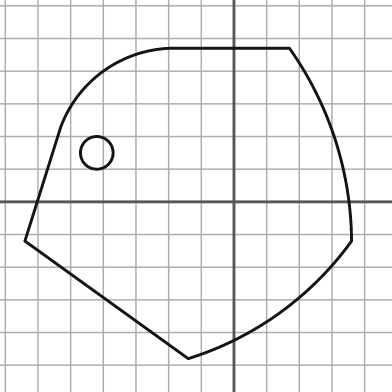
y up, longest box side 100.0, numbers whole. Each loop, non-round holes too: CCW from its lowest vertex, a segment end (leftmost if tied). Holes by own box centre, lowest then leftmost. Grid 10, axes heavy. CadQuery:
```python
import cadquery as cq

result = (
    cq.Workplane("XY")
    .moveTo(-14.0, -48.0)
    .threePointArc((14.0, -34.0), (36.0, -12.0))
    .threePointArc((31.0, 19.0), (17.0, 47.0))
    .lineTo(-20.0, 47.0)
    .threePointArc((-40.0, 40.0), (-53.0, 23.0))
    .lineTo(-64.0, -12.0)
    .close()
    .moveTo(-42.0, 15.0)
    .circle(5.0)
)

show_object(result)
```